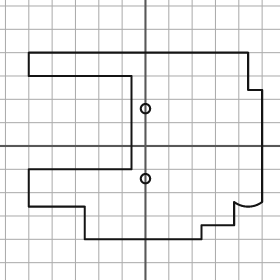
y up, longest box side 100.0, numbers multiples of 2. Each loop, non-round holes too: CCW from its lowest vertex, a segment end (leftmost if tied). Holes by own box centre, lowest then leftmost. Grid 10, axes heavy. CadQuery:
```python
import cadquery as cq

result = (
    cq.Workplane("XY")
    .moveTo(-26.0, -40.0)
    .lineTo(24.0, -40.0)
    .lineTo(24.0, -34.0)
    .lineTo(38.0, -34.0)
    .lineTo(38.0, -24.0)
    .threePointArc((44.0, -26.0), (50.0, -24.0))
    .lineTo(50.0, 24.0)
    .lineTo(44.0, 24.0)
    .lineTo(44.0, 40.0)
    .lineTo(-50.0, 40.0)
    .lineTo(-50.0, 30.0)
    .lineTo(-6.0, 30.0)
    .lineTo(-6.0, -10.0)
    .lineTo(-50.0, -10.0)
    .lineTo(-50.0, -26.0)
    .lineTo(-26.0, -26.0)
    .close()
    .moveTo(0.0, -14.0)
    .circle(2.0)
    .moveTo(0.0, 16.0)
    .circle(2.0)
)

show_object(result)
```